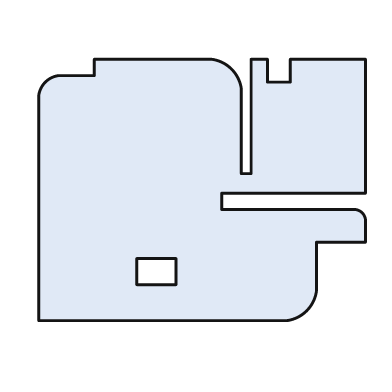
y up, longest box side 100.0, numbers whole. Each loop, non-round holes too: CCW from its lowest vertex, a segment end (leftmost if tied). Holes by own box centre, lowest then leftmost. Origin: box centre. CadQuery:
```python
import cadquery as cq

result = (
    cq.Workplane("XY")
    .moveTo(-50.0, -40.0)
    .lineTo(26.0, -40.0)
    .threePointArc((32.0, -37.0), (35.0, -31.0))
    .lineTo(35.0, -16.0)
    .lineTo(50.0, -16.0)
    .lineTo(50.0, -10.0)
    .threePointArc((49.0, -7.0), (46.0, -6.0))
    .lineTo(6.0, -6.0)
    .lineTo(6.0, -1.0)
    .lineTo(50.0, -1.0)
    .lineTo(50.0, 40.0)
    .lineTo(27.0, 40.0)
    .lineTo(27.0, 33.0)
    .lineTo(20.0, 33.0)
    .lineTo(20.0, 40.0)
    .lineTo(15.0, 40.0)
    .lineTo(15.0, 5.0)
    .lineTo(12.0, 5.0)
    .lineTo(12.0, 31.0)
    .threePointArc((9.0, 37.0), (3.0, 40.0))
    .lineTo(-33.0, 40.0)
    .lineTo(-33.0, 35.0)
    .lineTo(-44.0, 35.0)
    .threePointArc((-48.0, 33.0), (-50.0, 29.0))
    .close()
    .moveTo(-20.0, -29.0)
    .lineTo(-8.0, -29.0)
    .lineTo(-8.0, -21.0)
    .lineTo(-20.0, -21.0)
    .close()
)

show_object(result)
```